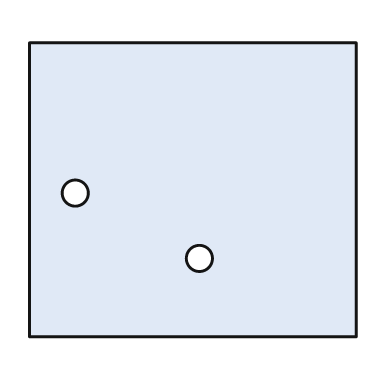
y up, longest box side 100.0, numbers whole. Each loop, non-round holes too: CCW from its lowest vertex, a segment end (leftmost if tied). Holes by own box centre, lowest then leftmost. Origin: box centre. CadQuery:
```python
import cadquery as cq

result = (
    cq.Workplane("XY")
    .moveTo(-50.0, -45.0)
    .lineTo(50.0, -45.0)
    .lineTo(50.0, 45.0)
    .lineTo(-50.0, 45.0)
    .close()
    .moveTo(2.0, -21.0)
    .circle(4.0)
    .moveTo(-36.0, -1.0)
    .circle(4.0)
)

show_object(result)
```